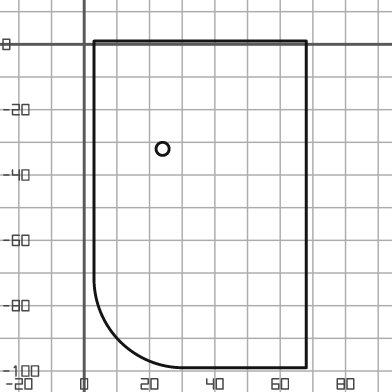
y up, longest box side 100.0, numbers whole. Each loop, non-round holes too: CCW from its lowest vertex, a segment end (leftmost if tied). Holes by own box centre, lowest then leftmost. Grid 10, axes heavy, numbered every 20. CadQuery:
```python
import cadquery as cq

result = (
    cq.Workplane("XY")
    .moveTo(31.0, -99.0)
    .lineTo(68.0, -99.0)
    .lineTo(68.0, 1.0)
    .lineTo(3.0, 1.0)
    .lineTo(3.0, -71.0)
    .threePointArc((11.0, -91.0), (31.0, -99.0))
    .close()
    .moveTo(24.0, -32.0)
    .circle(2.0)
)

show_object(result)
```